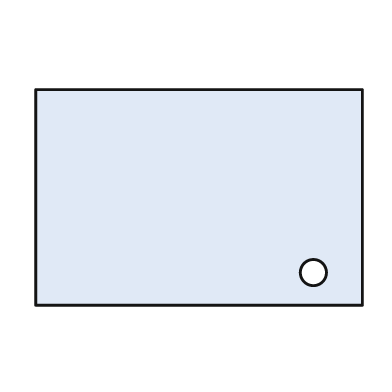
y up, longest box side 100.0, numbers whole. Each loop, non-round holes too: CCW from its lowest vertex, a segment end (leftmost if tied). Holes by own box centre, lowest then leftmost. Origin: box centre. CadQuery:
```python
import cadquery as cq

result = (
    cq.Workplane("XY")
    .moveTo(-50.0, -33.0)
    .lineTo(50.0, -33.0)
    .lineTo(50.0, 33.0)
    .lineTo(-50.0, 33.0)
    .close()
    .moveTo(35.0, -23.0)
    .circle(4.0)
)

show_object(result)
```